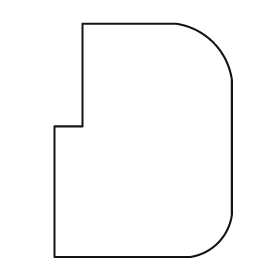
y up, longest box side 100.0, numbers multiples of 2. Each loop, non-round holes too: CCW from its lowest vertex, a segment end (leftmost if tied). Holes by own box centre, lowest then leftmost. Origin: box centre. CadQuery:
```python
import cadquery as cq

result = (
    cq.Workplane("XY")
    .moveTo(-38.0, -50.0)
    .lineTo(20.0, -50.0)
    .threePointArc((32.0, -44.0), (38.0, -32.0))
    .lineTo(38.0, 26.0)
    .threePointArc((30.0, 42.0), (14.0, 50.0))
    .lineTo(-26.0, 50.0)
    .lineTo(-26.0, 6.0)
    .lineTo(-38.0, 6.0)
    .close()
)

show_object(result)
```